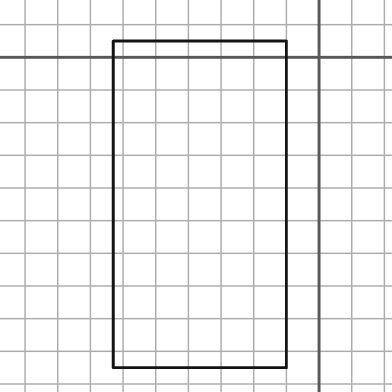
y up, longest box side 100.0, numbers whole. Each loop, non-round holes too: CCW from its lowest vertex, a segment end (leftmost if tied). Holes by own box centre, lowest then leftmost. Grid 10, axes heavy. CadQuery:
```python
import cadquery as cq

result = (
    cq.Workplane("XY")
    .moveTo(-63.0, -95.0)
    .lineTo(-10.0, -95.0)
    .lineTo(-10.0, 5.0)
    .lineTo(-63.0, 5.0)
    .close()
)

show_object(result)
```